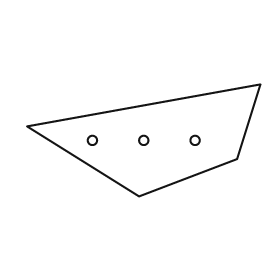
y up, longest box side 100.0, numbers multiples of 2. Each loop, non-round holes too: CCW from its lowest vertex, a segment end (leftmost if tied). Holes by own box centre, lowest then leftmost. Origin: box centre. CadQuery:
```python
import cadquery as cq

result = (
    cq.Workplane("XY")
    .moveTo(-2.0, -24.0)
    .lineTo(40.0, -8.0)
    .lineTo(50.0, 24.0)
    .lineTo(-50.0, 6.0)
    .close()
    .moveTo(-22.0, 0.0)
    .circle(2.0)
    .moveTo(0.0, 0.0)
    .circle(2.0)
    .moveTo(22.0, 0.0)
    .circle(2.0)
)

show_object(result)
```